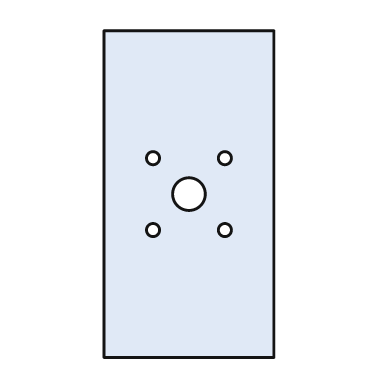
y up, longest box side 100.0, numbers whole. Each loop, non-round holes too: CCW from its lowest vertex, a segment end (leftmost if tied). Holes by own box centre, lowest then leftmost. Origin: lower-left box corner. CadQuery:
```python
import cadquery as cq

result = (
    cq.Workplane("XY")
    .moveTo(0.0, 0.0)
    .lineTo(52.0, 0.0)
    .lineTo(52.0, 100.0)
    .lineTo(0.0, 100.0)
    .close()
    .moveTo(15.0, 39.0)
    .circle(2.0)
    .moveTo(37.0, 39.0)
    .circle(2.0)
    .moveTo(26.0, 50.0)
    .circle(5.0)
    .moveTo(15.0, 61.0)
    .circle(2.0)
    .moveTo(37.0, 61.0)
    .circle(2.0)
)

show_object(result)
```